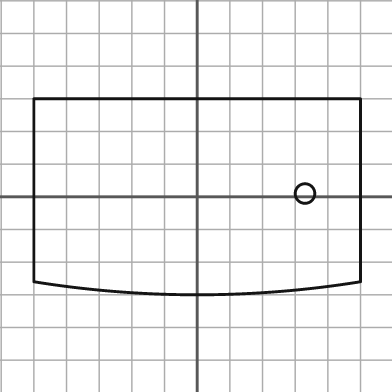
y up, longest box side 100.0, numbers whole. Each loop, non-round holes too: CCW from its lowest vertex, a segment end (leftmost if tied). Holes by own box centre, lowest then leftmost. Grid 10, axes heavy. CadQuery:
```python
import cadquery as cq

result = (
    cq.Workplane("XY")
    .moveTo(-50.0, -26.0)
    .threePointArc((0.0, -30.0), (50.0, -26.0))
    .lineTo(50.0, 30.0)
    .lineTo(-50.0, 30.0)
    .close()
    .moveTo(33.0, 1.0)
    .circle(3.0)
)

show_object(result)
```